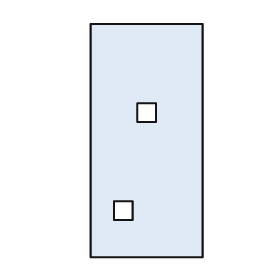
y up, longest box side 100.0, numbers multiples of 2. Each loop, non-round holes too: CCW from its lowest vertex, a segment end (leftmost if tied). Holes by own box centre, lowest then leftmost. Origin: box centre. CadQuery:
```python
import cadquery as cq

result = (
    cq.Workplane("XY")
    .moveTo(-24.0, -50.0)
    .lineTo(24.0, -50.0)
    .lineTo(24.0, 50.0)
    .lineTo(-24.0, 50.0)
    .close()
    .moveTo(-14.0, -34.0)
    .lineTo(-6.0, -34.0)
    .lineTo(-6.0, -26.0)
    .lineTo(-14.0, -26.0)
    .close()
    .moveTo(-4.0, 8.0)
    .lineTo(4.0, 8.0)
    .lineTo(4.0, 16.0)
    .lineTo(-4.0, 16.0)
    .close()
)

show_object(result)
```